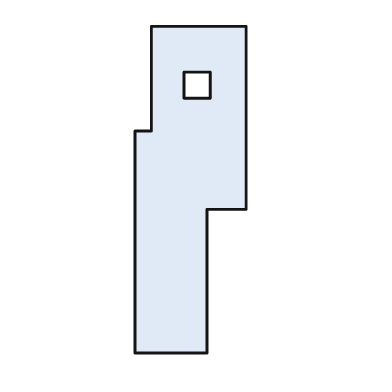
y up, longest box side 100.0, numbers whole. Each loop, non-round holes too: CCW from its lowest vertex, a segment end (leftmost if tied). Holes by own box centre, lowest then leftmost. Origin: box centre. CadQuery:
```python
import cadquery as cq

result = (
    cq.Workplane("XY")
    .moveTo(-17.0, -50.0)
    .lineTo(5.0, -50.0)
    .lineTo(5.0, -6.0)
    .lineTo(17.0, -6.0)
    .lineTo(17.0, 50.0)
    .lineTo(-12.0, 50.0)
    .lineTo(-12.0, 18.0)
    .lineTo(-17.0, 18.0)
    .close()
    .moveTo(-2.0, 28.0)
    .lineTo(6.0, 28.0)
    .lineTo(6.0, 36.0)
    .lineTo(-2.0, 36.0)
    .close()
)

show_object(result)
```